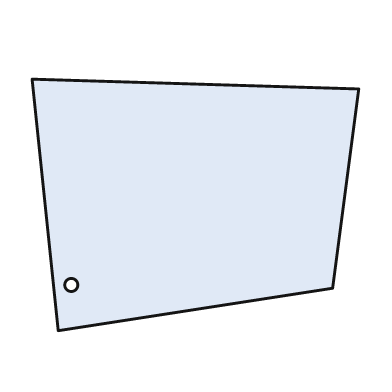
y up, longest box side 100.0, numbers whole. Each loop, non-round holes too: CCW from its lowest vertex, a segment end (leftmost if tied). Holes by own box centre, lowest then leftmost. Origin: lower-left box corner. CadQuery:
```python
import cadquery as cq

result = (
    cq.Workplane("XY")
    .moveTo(8.0, 0.0)
    .lineTo(92.0, 13.0)
    .lineTo(100.0, 74.0)
    .lineTo(0.0, 77.0)
    .close()
    .moveTo(12.0, 14.0)
    .circle(2.0)
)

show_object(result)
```